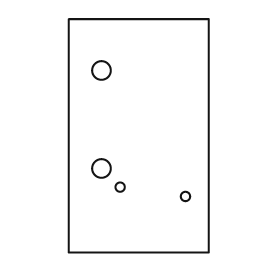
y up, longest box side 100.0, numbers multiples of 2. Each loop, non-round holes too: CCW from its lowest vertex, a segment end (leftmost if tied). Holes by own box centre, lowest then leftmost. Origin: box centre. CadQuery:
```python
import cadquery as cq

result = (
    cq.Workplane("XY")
    .moveTo(-30.0, -50.0)
    .lineTo(30.0, -50.0)
    .lineTo(30.0, 50.0)
    .lineTo(-30.0, 50.0)
    .close()
    .moveTo(20.0, -26.0)
    .circle(2.0)
    .moveTo(-8.0, -22.0)
    .circle(2.0)
    .moveTo(-16.0, -14.0)
    .circle(4.0)
    .moveTo(-16.0, 28.0)
    .circle(4.0)
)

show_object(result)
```